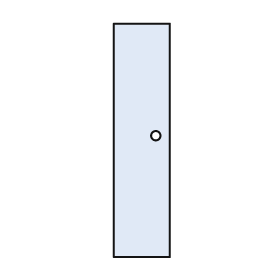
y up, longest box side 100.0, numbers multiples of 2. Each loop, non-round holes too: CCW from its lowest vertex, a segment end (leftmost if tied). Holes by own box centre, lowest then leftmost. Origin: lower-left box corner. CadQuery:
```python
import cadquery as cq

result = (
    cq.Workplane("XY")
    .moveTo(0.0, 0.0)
    .lineTo(24.0, 0.0)
    .lineTo(24.0, 100.0)
    .lineTo(0.0, 100.0)
    .close()
    .moveTo(18.0, 52.0)
    .circle(2.0)
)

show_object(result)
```